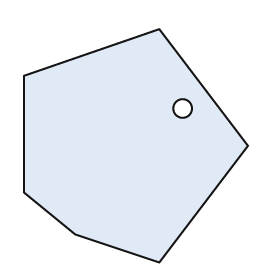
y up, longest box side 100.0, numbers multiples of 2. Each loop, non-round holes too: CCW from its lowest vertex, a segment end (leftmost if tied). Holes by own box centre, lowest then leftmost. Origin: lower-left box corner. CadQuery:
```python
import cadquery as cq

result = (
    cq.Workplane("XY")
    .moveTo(58.0, 0.0)
    .lineTo(96.0, 50.0)
    .lineTo(58.0, 100.0)
    .lineTo(0.0, 80.0)
    .lineTo(0.0, 30.0)
    .lineTo(22.0, 12.0)
    .close()
    .moveTo(68.0, 66.0)
    .circle(4.0)
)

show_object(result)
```